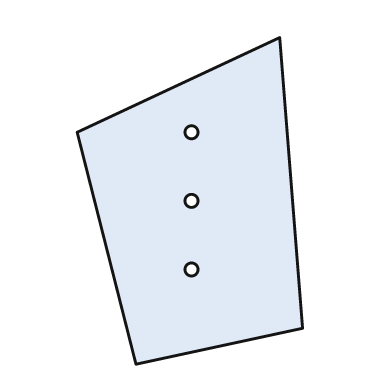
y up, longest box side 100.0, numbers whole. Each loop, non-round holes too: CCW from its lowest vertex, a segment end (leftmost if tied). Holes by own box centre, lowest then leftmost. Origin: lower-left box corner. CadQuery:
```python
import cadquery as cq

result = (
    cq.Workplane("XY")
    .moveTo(18.0, 0.0)
    .lineTo(69.0, 11.0)
    .lineTo(62.0, 100.0)
    .lineTo(0.0, 71.0)
    .close()
    .moveTo(35.0, 29.0)
    .circle(2.0)
    .moveTo(35.0, 50.0)
    .circle(2.0)
    .moveTo(35.0, 71.0)
    .circle(2.0)
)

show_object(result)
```